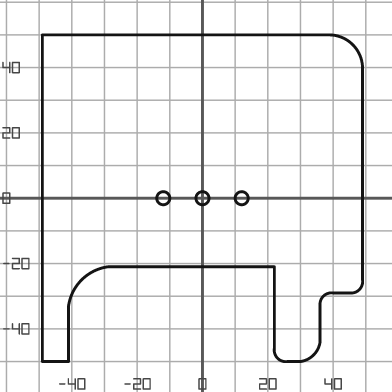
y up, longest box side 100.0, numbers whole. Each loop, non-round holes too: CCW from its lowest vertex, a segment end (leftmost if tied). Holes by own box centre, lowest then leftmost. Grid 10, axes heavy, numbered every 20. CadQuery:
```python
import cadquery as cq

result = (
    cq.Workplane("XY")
    .moveTo(-49.0, -50.0)
    .lineTo(-41.0, -50.0)
    .lineTo(-41.0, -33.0)
    .threePointArc((-37.0, -25.0), (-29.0, -21.0))
    .lineTo(22.0, -21.0)
    .lineTo(22.0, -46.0)
    .threePointArc((23.0, -49.0), (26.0, -50.0))
    .lineTo(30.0, -50.0)
    .threePointArc((34.0, -48.0), (36.0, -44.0))
    .lineTo(36.0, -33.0)
    .threePointArc((37.0, -30.0), (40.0, -29.0))
    .lineTo(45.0, -29.0)
    .threePointArc((48.0, -28.0), (49.0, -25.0))
    .lineTo(49.0, 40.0)
    .threePointArc((46.0, 47.0), (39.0, 50.0))
    .lineTo(-49.0, 50.0)
    .close()
    .moveTo(-12.0, 0.0)
    .circle(2.0)
    .moveTo(0.0, 0.0)
    .circle(2.0)
    .moveTo(12.0, 0.0)
    .circle(2.0)
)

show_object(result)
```